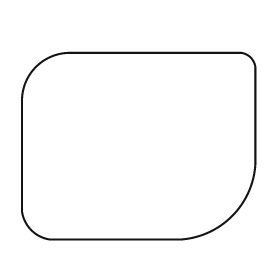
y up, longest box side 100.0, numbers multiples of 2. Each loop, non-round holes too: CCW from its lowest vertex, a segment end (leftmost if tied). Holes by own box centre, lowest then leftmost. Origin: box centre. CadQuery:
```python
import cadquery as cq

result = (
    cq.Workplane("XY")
    .moveTo(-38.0, -40.0)
    .lineTo(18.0, -40.0)
    .threePointArc((40.0, -30.0), (50.0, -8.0))
    .lineTo(50.0, 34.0)
    .threePointArc((48.0, 38.0), (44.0, 40.0))
    .lineTo(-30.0, 40.0)
    .threePointArc((-44.0, 34.0), (-50.0, 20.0))
    .lineTo(-50.0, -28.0)
    .threePointArc((-46.0, -36.0), (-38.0, -40.0))
    .close()
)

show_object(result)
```